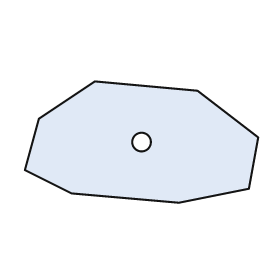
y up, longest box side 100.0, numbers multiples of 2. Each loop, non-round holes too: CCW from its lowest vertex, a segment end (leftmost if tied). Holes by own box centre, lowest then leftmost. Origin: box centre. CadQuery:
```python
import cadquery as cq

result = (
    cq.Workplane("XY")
    .moveTo(16.0, -26.0)
    .lineTo(46.0, -20.0)
    .lineTo(50.0, 2.0)
    .lineTo(24.0, 22.0)
    .lineTo(-20.0, 26.0)
    .lineTo(-44.0, 10.0)
    .lineTo(-50.0, -12.0)
    .lineTo(-30.0, -22.0)
    .close()
    .moveTo(0.0, 0.0)
    .circle(4.0)
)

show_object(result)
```